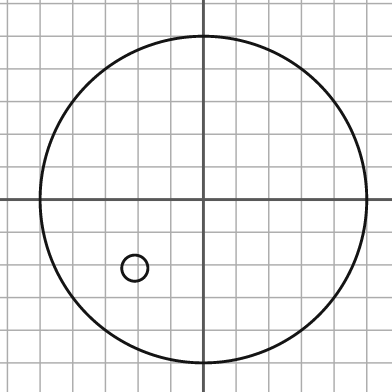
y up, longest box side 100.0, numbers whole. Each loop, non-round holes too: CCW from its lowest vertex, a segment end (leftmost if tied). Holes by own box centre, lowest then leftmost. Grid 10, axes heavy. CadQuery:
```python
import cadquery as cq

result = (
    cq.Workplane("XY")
    .moveTo(0.0, 0.0)
    .circle(50.0)
    .moveTo(-21.0, -21.0)
    .circle(4.0)
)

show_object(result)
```